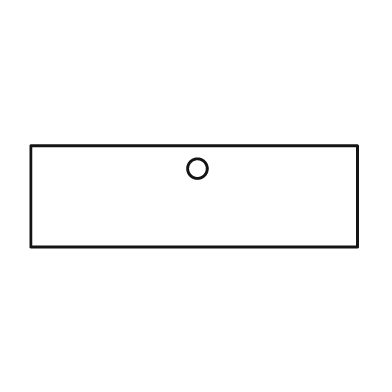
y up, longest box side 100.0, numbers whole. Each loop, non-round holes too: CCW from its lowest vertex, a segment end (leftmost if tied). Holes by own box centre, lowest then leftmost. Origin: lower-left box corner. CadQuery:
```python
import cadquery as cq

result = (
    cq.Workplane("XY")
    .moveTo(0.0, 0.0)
    .lineTo(100.0, 0.0)
    .lineTo(100.0, 31.0)
    .lineTo(0.0, 31.0)
    .close()
    .moveTo(51.0, 24.0)
    .circle(3.0)
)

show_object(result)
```